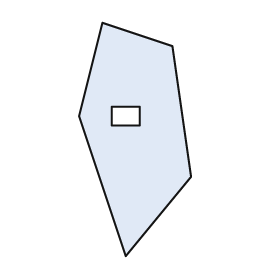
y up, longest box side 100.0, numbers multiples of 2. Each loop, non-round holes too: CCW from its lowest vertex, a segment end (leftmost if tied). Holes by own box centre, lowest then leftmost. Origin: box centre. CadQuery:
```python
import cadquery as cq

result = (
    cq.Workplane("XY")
    .moveTo(-4.0, -50.0)
    .lineTo(24.0, -16.0)
    .lineTo(16.0, 40.0)
    .lineTo(-14.0, 50.0)
    .lineTo(-24.0, 10.0)
    .close()
    .moveTo(-10.0, 6.0)
    .lineTo(2.0, 6.0)
    .lineTo(2.0, 14.0)
    .lineTo(-10.0, 14.0)
    .close()
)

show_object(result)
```